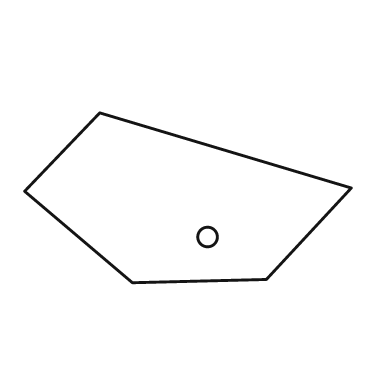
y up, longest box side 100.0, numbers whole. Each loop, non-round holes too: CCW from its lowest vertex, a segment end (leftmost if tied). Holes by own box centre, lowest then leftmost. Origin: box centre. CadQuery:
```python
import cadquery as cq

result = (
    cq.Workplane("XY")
    .moveTo(-17.0, -26.0)
    .lineTo(24.0, -25.0)
    .lineTo(50.0, 3.0)
    .lineTo(-27.0, 26.0)
    .lineTo(-50.0, 2.0)
    .close()
    .moveTo(6.0, -12.0)
    .circle(3.0)
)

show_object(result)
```